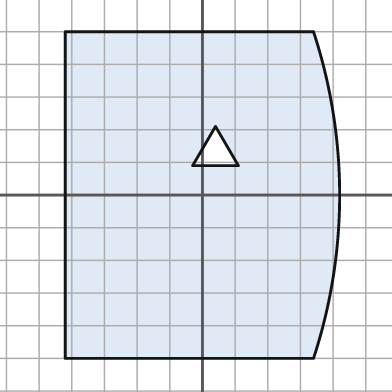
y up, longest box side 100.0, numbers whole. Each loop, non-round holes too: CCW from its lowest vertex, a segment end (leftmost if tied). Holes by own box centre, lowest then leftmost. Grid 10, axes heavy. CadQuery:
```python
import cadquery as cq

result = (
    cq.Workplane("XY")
    .moveTo(-42.0, -50.0)
    .lineTo(34.0, -50.0)
    .threePointArc((42.0, 0.0), (34.0, 50.0))
    .lineTo(-42.0, 50.0)
    .close()
    .moveTo(-3.0, 9.0)
    .lineTo(11.0, 9.0)
    .lineTo(4.0, 21.0)
    .close()
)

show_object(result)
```